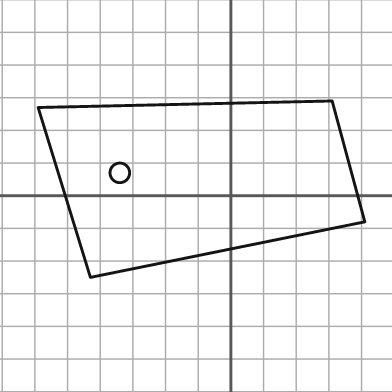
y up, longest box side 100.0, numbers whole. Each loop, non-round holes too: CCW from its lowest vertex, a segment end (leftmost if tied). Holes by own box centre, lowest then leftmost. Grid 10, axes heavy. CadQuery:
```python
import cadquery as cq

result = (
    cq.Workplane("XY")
    .moveTo(-43.0, -25.0)
    .lineTo(41.0, -8.0)
    .lineTo(31.0, 29.0)
    .lineTo(-59.0, 27.0)
    .close()
    .moveTo(-34.0, 7.0)
    .circle(3.0)
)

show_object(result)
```